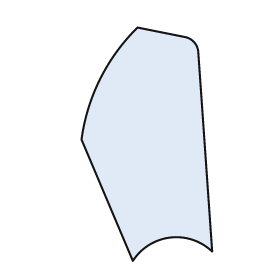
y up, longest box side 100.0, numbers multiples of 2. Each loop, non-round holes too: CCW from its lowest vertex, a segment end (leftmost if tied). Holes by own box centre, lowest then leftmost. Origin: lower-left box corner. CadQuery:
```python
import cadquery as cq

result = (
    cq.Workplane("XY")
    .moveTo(22.0, 0.0)
    .threePointArc((38.0, 10.0), (56.0, 4.0))
    .lineTo(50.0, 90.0)
    .threePointArc((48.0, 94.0), (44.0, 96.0))
    .lineTo(24.0, 100.0)
    .threePointArc((8.0, 78.0), (0.0, 52.0))
    .close()
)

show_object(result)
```